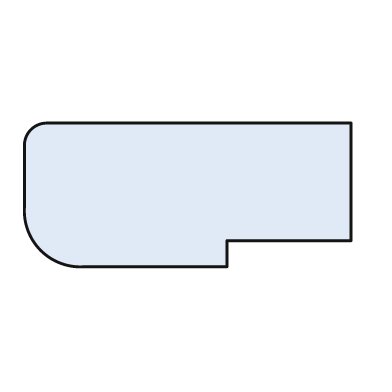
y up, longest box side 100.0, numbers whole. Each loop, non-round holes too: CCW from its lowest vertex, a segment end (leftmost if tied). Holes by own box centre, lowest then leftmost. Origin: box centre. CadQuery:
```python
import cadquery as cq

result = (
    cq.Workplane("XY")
    .moveTo(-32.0, -22.0)
    .lineTo(12.0, -22.0)
    .lineTo(12.0, -14.0)
    .lineTo(50.0, -14.0)
    .lineTo(50.0, 22.0)
    .lineTo(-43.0, 22.0)
    .threePointArc((-48.0, 20.0), (-50.0, 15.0))
    .lineTo(-50.0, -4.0)
    .threePointArc((-45.0, -17.0), (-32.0, -22.0))
    .close()
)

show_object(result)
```